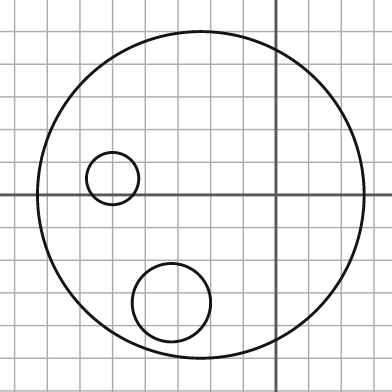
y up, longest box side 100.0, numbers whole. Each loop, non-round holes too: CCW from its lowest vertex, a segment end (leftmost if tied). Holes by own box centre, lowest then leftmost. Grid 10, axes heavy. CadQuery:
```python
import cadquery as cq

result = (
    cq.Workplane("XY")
    .moveTo(-23.0, 0.0)
    .circle(50.0)
    .moveTo(-32.0, -33.0)
    .circle(12.0)
    .moveTo(-50.0, 5.0)
    .circle(8.0)
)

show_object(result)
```